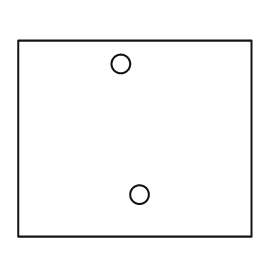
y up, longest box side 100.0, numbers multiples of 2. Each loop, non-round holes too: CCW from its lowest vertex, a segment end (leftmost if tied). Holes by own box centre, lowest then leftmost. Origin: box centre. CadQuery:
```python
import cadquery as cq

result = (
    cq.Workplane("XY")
    .moveTo(-50.0, -42.0)
    .lineTo(50.0, -42.0)
    .lineTo(50.0, 42.0)
    .lineTo(-50.0, 42.0)
    .close()
    .moveTo(2.0, -24.0)
    .circle(4.0)
    .moveTo(-6.0, 32.0)
    .circle(4.0)
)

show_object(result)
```